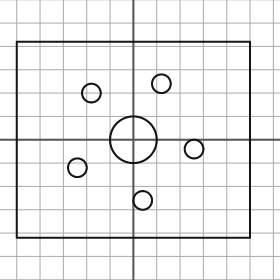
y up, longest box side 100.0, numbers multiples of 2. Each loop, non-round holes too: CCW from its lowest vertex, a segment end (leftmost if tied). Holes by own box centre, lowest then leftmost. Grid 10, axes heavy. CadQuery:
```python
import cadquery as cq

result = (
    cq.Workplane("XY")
    .moveTo(-50.0, -42.0)
    .lineTo(50.0, -42.0)
    .lineTo(50.0, 42.0)
    .lineTo(-50.0, 42.0)
    .close()
    .moveTo(4.0, -26.0)
    .circle(4.0)
    .moveTo(-24.0, -12.0)
    .circle(4.0)
    .moveTo(26.0, -4.0)
    .circle(4.0)
    .moveTo(0.0, 0.0)
    .circle(10.0)
    .moveTo(-18.0, 20.0)
    .circle(4.0)
    .moveTo(12.0, 24.0)
    .circle(4.0)
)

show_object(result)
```